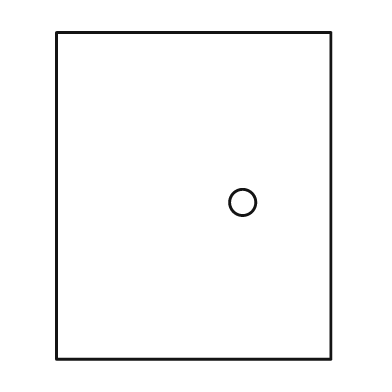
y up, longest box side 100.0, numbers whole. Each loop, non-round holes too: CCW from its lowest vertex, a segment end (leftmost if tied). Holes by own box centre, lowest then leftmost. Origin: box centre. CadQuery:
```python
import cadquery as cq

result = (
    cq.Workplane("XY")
    .moveTo(-42.0, -50.0)
    .lineTo(42.0, -50.0)
    .lineTo(42.0, 50.0)
    .lineTo(-42.0, 50.0)
    .close()
    .moveTo(15.0, -2.0)
    .circle(4.0)
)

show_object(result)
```